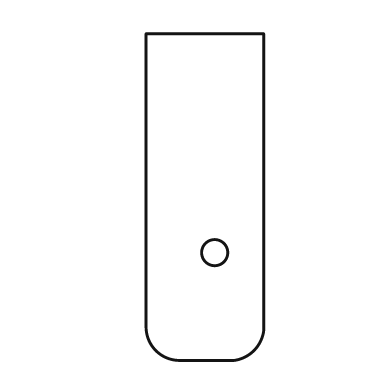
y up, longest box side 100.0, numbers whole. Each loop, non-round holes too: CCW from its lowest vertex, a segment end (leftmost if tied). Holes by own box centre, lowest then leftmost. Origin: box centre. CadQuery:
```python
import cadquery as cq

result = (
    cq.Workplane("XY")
    .moveTo(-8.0, -50.0)
    .lineTo(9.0, -50.0)
    .threePointArc((15.0, -47.0), (18.0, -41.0))
    .lineTo(18.0, 50.0)
    .lineTo(-18.0, 50.0)
    .lineTo(-18.0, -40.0)
    .threePointArc((-15.0, -47.0), (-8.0, -50.0))
    .close()
    .moveTo(3.0, -17.0)
    .circle(4.0)
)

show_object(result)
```